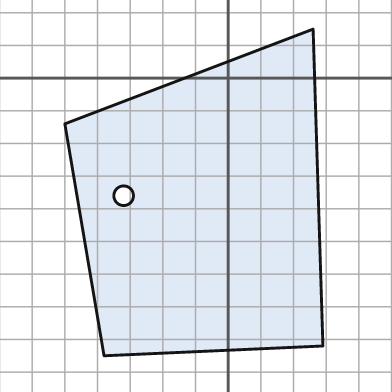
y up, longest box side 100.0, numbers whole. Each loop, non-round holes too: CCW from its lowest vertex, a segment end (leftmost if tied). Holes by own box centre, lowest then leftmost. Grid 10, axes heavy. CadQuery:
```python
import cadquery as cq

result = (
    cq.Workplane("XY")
    .moveTo(-38.0, -85.0)
    .lineTo(29.0, -82.0)
    .lineTo(26.0, 15.0)
    .lineTo(-50.0, -14.0)
    .close()
    .moveTo(-32.0, -36.0)
    .circle(3.0)
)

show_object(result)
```